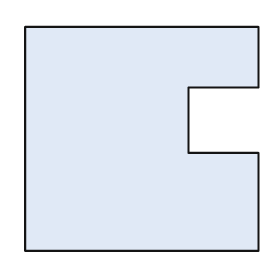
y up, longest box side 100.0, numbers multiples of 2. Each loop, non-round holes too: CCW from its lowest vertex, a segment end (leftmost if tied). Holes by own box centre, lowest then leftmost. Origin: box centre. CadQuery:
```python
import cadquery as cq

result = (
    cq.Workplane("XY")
    .moveTo(-50.0, -48.0)
    .lineTo(50.0, -48.0)
    .lineTo(50.0, -6.0)
    .lineTo(20.0, -6.0)
    .lineTo(20.0, 22.0)
    .lineTo(50.0, 22.0)
    .lineTo(50.0, 48.0)
    .lineTo(-50.0, 48.0)
    .close()
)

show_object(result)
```